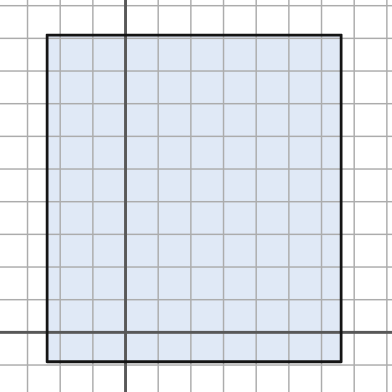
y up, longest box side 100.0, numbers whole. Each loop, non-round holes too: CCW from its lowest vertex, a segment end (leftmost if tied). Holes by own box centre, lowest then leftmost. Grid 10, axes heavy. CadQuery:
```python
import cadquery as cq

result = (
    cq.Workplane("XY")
    .moveTo(-24.0, -9.0)
    .lineTo(66.0, -9.0)
    .lineTo(66.0, 91.0)
    .lineTo(-24.0, 91.0)
    .close()
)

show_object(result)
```